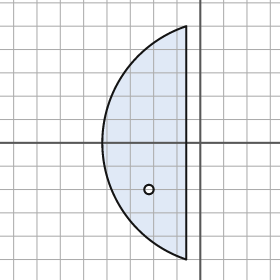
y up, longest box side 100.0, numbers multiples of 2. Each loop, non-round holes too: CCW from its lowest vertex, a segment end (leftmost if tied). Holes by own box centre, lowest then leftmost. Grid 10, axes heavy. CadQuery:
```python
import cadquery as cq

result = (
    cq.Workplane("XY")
    .moveTo(-6.0, -50.0)
    .lineTo(-6.0, 50.0)
    .threePointArc((-42.0, 0.0), (-6.0, -50.0))
    .close()
    .moveTo(-22.0, -20.0)
    .circle(2.0)
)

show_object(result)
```